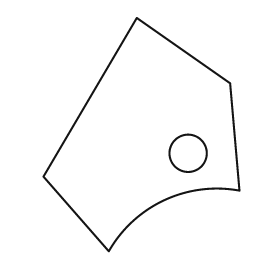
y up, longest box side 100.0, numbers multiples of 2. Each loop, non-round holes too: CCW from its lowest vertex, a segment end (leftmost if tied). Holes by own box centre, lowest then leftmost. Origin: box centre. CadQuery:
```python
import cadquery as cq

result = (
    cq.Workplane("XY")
    .moveTo(-14.0, -50.0)
    .threePointArc((10.0, -28.0), (42.0, -24.0))
    .lineTo(38.0, 22.0)
    .lineTo(-2.0, 50.0)
    .lineTo(-42.0, -18.0)
    .close()
    .moveTo(20.0, -8.0)
    .circle(8.0)
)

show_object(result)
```